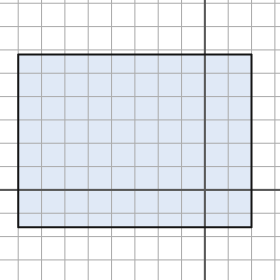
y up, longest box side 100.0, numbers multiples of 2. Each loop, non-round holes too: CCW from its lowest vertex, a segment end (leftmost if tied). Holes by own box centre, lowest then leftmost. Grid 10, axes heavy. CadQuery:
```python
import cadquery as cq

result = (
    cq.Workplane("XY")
    .moveTo(-80.0, -16.0)
    .lineTo(20.0, -16.0)
    .lineTo(20.0, 58.0)
    .lineTo(-80.0, 58.0)
    .close()
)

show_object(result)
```